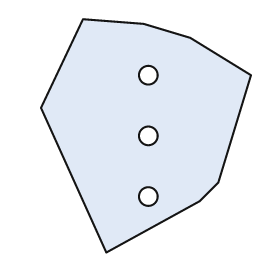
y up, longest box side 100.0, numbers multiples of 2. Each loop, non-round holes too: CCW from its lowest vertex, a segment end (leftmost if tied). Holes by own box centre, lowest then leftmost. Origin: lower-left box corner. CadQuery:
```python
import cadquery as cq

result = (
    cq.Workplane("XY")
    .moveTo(28.0, 0.0)
    .lineTo(68.0, 22.0)
    .lineTo(76.0, 30.0)
    .lineTo(90.0, 76.0)
    .lineTo(64.0, 92.0)
    .lineTo(44.0, 98.0)
    .lineTo(18.0, 100.0)
    .lineTo(0.0, 62.0)
    .close()
    .moveTo(46.0, 24.0)
    .circle(4.0)
    .moveTo(46.0, 50.0)
    .circle(4.0)
    .moveTo(46.0, 76.0)
    .circle(4.0)
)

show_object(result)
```